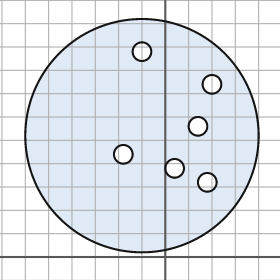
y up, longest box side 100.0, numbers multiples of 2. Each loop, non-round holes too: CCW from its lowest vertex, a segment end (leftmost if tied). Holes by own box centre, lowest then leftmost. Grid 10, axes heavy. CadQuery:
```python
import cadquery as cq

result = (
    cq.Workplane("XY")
    .moveTo(-10.0, 52.0)
    .circle(50.0)
    .moveTo(18.0, 32.0)
    .circle(4.0)
    .moveTo(4.0, 38.0)
    .circle(4.0)
    .moveTo(-18.0, 44.0)
    .circle(4.0)
    .moveTo(14.0, 56.0)
    .circle(4.0)
    .moveTo(20.0, 74.0)
    .circle(4.0)
    .moveTo(-10.0, 88.0)
    .circle(4.0)
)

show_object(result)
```